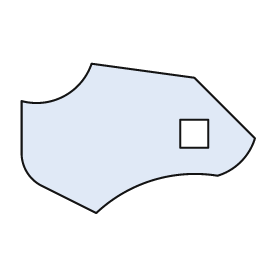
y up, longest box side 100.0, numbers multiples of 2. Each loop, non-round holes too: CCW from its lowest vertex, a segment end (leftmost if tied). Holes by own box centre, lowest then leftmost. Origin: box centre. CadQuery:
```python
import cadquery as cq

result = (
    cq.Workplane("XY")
    .moveTo(-18.0, -32.0)
    .threePointArc((6.0, -18.0), (34.0, -16.0))
    .threePointArc((44.0, -10.0), (50.0, 0.0))
    .lineTo(24.0, 26.0)
    .lineTo(-20.0, 32.0)
    .threePointArc((-32.0, 18.0), (-50.0, 16.0))
    .lineTo(-50.0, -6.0)
    .threePointArc((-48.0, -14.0), (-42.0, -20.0))
    .close()
    .moveTo(18.0, -4.0)
    .lineTo(30.0, -4.0)
    .lineTo(30.0, 8.0)
    .lineTo(18.0, 8.0)
    .close()
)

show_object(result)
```